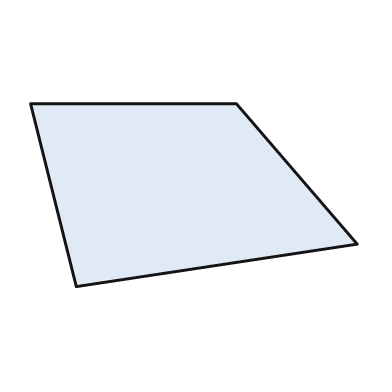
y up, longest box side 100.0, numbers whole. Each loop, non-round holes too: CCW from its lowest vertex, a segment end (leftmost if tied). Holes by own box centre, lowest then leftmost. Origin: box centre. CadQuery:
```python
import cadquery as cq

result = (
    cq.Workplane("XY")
    .moveTo(-36.0, -28.0)
    .lineTo(50.0, -15.0)
    .lineTo(13.0, 28.0)
    .lineTo(-50.0, 28.0)
    .close()
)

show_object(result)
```